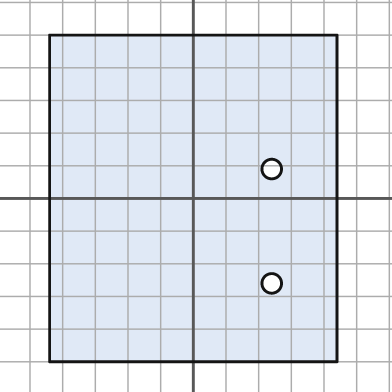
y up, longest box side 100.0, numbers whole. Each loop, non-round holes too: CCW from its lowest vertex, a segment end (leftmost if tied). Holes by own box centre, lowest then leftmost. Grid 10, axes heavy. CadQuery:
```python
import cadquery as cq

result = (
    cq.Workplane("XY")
    .moveTo(-44.0, -50.0)
    .lineTo(44.0, -50.0)
    .lineTo(44.0, 50.0)
    .lineTo(-44.0, 50.0)
    .close()
    .moveTo(24.0, -26.0)
    .circle(3.0)
    .moveTo(24.0, 9.0)
    .circle(3.0)
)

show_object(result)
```